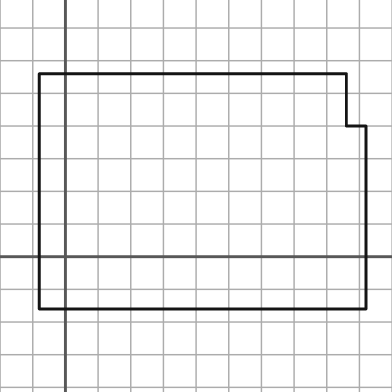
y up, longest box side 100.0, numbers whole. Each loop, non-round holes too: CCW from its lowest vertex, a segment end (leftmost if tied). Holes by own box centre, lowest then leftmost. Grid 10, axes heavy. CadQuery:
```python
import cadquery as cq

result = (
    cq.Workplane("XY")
    .moveTo(-8.0, -16.0)
    .lineTo(92.0, -16.0)
    .lineTo(92.0, 40.0)
    .lineTo(86.0, 40.0)
    .lineTo(86.0, 56.0)
    .lineTo(-8.0, 56.0)
    .close()
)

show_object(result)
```